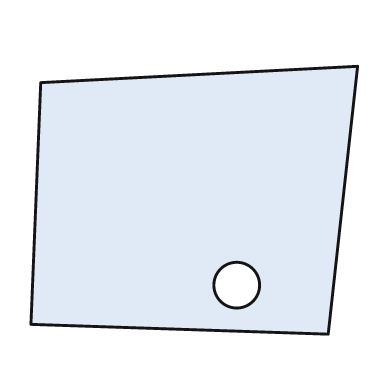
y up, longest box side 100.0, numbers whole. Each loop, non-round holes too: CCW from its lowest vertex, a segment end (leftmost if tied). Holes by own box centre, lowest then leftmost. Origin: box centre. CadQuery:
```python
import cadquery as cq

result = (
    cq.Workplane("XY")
    .moveTo(41.0, -41.0)
    .lineTo(50.0, 41.0)
    .lineTo(-47.0, 36.0)
    .lineTo(-50.0, -38.0)
    .close()
    .moveTo(13.0, -26.0)
    .circle(7.0)
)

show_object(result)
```